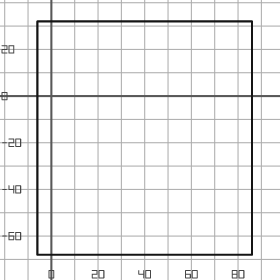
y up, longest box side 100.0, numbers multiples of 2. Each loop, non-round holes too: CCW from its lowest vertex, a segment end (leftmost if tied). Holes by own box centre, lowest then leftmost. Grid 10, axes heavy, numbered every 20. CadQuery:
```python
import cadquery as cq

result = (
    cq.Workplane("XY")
    .moveTo(-6.0, -68.0)
    .lineTo(86.0, -68.0)
    .lineTo(86.0, 32.0)
    .lineTo(-6.0, 32.0)
    .close()
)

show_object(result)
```